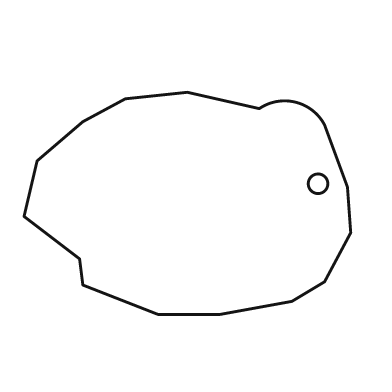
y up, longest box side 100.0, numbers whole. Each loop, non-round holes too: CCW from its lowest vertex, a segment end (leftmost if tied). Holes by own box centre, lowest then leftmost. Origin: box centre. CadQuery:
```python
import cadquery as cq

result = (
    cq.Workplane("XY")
    .moveTo(-9.0, -34.0)
    .lineTo(10.0, -34.0)
    .lineTo(32.0, -30.0)
    .lineTo(42.0, -24.0)
    .lineTo(50.0, -9.0)
    .lineTo(49.0, 5.0)
    .lineTo(42.0, 24.0)
    .threePointArc((33.0, 31.0), (22.0, 29.0))
    .lineTo(0.0, 34.0)
    .lineTo(-19.0, 32.0)
    .lineTo(-32.0, 25.0)
    .lineTo(-46.0, 13.0)
    .lineTo(-50.0, -4.0)
    .lineTo(-33.0, -17.0)
    .lineTo(-32.0, -25.0)
    .close()
    .moveTo(40.0, 6.0)
    .circle(3.0)
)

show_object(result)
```